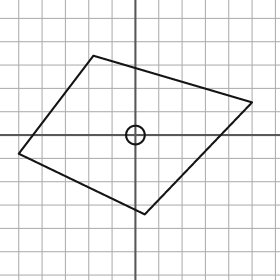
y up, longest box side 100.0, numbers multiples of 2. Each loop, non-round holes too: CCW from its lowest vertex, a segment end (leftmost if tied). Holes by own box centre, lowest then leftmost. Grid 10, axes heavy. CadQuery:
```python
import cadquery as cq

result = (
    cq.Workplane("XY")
    .moveTo(4.0, -34.0)
    .lineTo(50.0, 14.0)
    .lineTo(-18.0, 34.0)
    .lineTo(-50.0, -8.0)
    .close()
    .moveTo(0.0, 0.0)
    .circle(4.0)
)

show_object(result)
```